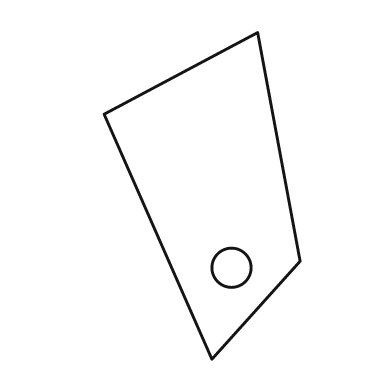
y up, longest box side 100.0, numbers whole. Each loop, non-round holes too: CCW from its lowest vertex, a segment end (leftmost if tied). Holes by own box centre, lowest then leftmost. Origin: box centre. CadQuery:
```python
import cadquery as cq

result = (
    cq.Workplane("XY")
    .moveTo(3.0, -50.0)
    .lineTo(30.0, -20.0)
    .lineTo(17.0, 50.0)
    .lineTo(-30.0, 25.0)
    .close()
    .moveTo(9.0, -22.0)
    .circle(6.0)
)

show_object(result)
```